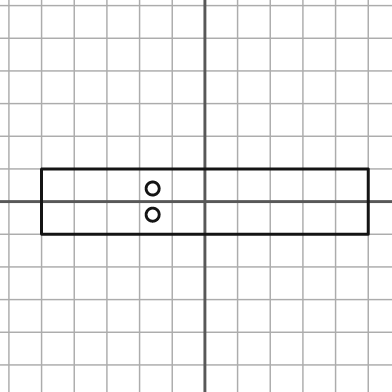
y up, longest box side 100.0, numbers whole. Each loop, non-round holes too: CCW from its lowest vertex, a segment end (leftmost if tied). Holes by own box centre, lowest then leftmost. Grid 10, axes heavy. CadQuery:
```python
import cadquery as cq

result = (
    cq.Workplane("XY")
    .moveTo(-50.0, -10.0)
    .lineTo(50.0, -10.0)
    .lineTo(50.0, 10.0)
    .lineTo(-50.0, 10.0)
    .close()
    .moveTo(-16.0, -4.0)
    .circle(2.0)
    .moveTo(-16.0, 4.0)
    .circle(2.0)
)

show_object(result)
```